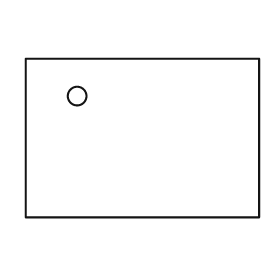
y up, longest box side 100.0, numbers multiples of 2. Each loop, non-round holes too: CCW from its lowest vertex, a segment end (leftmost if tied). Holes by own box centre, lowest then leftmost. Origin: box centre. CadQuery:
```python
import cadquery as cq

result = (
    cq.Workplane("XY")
    .moveTo(-50.0, -34.0)
    .lineTo(50.0, -34.0)
    .lineTo(50.0, 34.0)
    .lineTo(-50.0, 34.0)
    .close()
    .moveTo(-28.0, 18.0)
    .circle(4.0)
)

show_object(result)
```